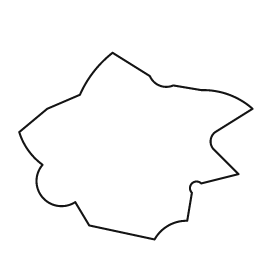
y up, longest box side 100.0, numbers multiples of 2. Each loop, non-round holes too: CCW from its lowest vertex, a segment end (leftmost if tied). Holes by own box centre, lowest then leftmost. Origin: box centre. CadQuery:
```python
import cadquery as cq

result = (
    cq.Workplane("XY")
    .moveTo(8.0, -40.0)
    .threePointArc((14.0, -34.0), (22.0, -32.0))
    .lineTo(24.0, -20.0)
    .threePointArc((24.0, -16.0), (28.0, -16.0))
    .lineTo(44.0, -12.0)
    .lineTo(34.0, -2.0)
    .threePointArc((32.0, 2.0), (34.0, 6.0))
    .lineTo(50.0, 16.0)
    .threePointArc((40.0, 22.0), (28.0, 24.0))
    .lineTo(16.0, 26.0)
    .threePointArc((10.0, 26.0), (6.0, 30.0))
    .lineTo(-10.0, 40.0)
    .threePointArc((-18.0, 32.0), (-24.0, 22.0))
    .lineTo(-38.0, 16.0)
    .lineTo(-50.0, 6.0)
    .threePointArc((-46.0, -2.0), (-40.0, -8.0))
    .threePointArc((-40.0, -22.0), (-26.0, -24.0))
    .lineTo(-20.0, -34.0)
    .close()
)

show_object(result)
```